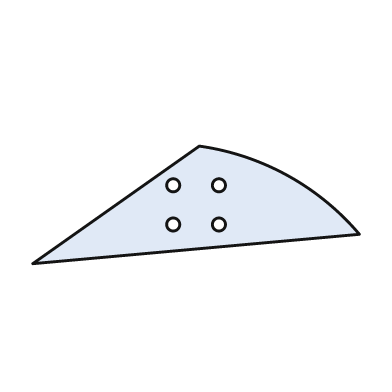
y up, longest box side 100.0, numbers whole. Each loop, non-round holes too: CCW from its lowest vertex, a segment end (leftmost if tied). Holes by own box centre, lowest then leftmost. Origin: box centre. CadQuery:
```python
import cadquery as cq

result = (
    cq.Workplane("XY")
    .moveTo(-50.0, -18.0)
    .lineTo(50.0, -9.0)
    .threePointArc((28.0, 9.0), (1.0, 18.0))
    .close()
    .moveTo(-7.0, -6.0)
    .circle(2.0)
    .moveTo(7.0, -6.0)
    .circle(2.0)
    .moveTo(-7.0, 6.0)
    .circle(2.0)
    .moveTo(7.0, 6.0)
    .circle(2.0)
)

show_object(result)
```